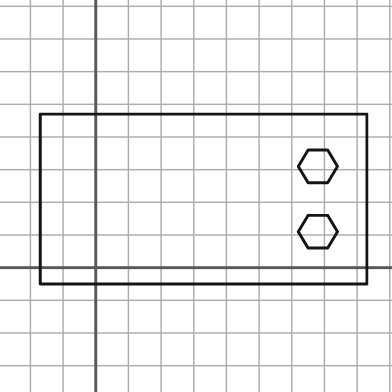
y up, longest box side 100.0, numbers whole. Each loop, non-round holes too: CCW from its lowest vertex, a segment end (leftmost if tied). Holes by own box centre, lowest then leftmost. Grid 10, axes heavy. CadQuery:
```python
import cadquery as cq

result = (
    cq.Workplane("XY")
    .moveTo(-17.0, -5.0)
    .lineTo(83.0, -5.0)
    .lineTo(83.0, 47.0)
    .lineTo(-17.0, 47.0)
    .close()
    .moveTo(65.0, 6.0)
    .lineTo(71.0, 6.0)
    .lineTo(74.0, 11.0)
    .lineTo(71.0, 16.0)
    .lineTo(65.0, 16.0)
    .lineTo(62.0, 11.0)
    .close()
    .moveTo(65.0, 26.0)
    .lineTo(71.0, 26.0)
    .lineTo(74.0, 31.0)
    .lineTo(71.0, 36.0)
    .lineTo(65.0, 36.0)
    .lineTo(62.0, 31.0)
    .close()
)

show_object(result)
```